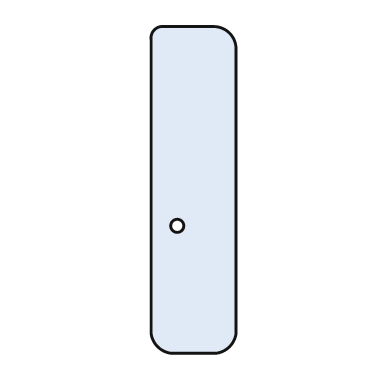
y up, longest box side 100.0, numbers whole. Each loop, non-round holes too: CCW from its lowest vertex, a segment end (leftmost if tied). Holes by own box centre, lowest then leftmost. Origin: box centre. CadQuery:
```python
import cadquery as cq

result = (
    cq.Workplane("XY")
    .moveTo(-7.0, -50.0)
    .lineTo(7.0, -50.0)
    .threePointArc((11.0, -48.0), (13.0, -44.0))
    .lineTo(13.0, 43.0)
    .threePointArc((11.0, 48.0), (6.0, 50.0))
    .lineTo(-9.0, 50.0)
    .threePointArc((-12.0, 49.0), (-13.0, 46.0))
    .lineTo(-13.0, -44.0)
    .threePointArc((-11.0, -48.0), (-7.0, -50.0))
    .close()
    .moveTo(-5.0, -11.0)
    .circle(2.0)
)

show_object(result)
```